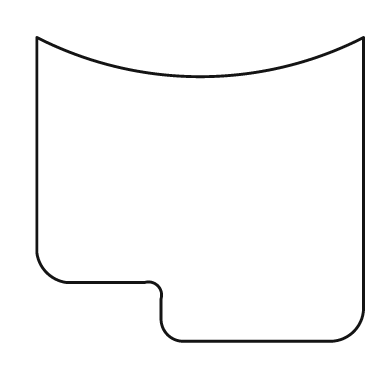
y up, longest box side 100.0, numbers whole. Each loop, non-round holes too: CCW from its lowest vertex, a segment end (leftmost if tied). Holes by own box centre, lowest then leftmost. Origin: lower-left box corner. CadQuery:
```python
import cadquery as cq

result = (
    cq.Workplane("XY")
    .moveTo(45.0, 0.0)
    .lineTo(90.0, 0.0)
    .threePointArc((97.0, 3.0), (100.0, 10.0))
    .lineTo(100.0, 93.0)
    .threePointArc((50.0, 81.0), (0.0, 93.0))
    .lineTo(0.0, 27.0)
    .threePointArc((3.0, 21.0), (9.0, 18.0))
    .lineTo(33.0, 18.0)
    .threePointArc((37.0, 17.0), (38.0, 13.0))
    .lineTo(38.0, 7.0)
    .threePointArc((40.0, 2.0), (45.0, 0.0))
    .close()
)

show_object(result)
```